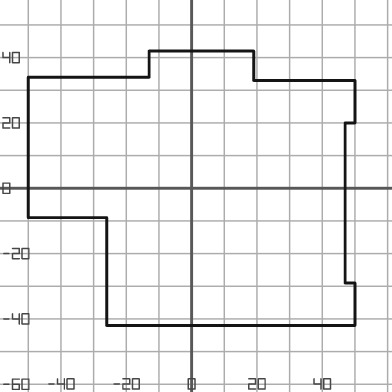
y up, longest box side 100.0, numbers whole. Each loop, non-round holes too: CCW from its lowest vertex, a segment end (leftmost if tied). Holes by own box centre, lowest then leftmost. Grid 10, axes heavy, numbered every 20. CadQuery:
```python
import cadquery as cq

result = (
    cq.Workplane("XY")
    .moveTo(-26.0, -42.0)
    .lineTo(50.0, -42.0)
    .lineTo(50.0, -29.0)
    .lineTo(47.0, -29.0)
    .lineTo(47.0, 20.0)
    .lineTo(50.0, 20.0)
    .lineTo(50.0, 33.0)
    .lineTo(19.0, 33.0)
    .lineTo(19.0, 42.0)
    .lineTo(-13.0, 42.0)
    .lineTo(-13.0, 34.0)
    .lineTo(-50.0, 34.0)
    .lineTo(-50.0, -9.0)
    .lineTo(-26.0, -9.0)
    .close()
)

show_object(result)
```